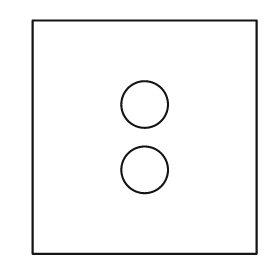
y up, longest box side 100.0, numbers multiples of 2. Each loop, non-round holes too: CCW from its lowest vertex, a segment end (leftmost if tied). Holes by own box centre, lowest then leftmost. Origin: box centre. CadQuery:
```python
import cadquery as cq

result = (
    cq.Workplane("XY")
    .moveTo(-48.0, -50.0)
    .lineTo(48.0, -50.0)
    .lineTo(48.0, 50.0)
    .lineTo(-48.0, 50.0)
    .close()
    .moveTo(0.0, -14.0)
    .circle(10.0)
    .moveTo(0.0, 14.0)
    .circle(10.0)
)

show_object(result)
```